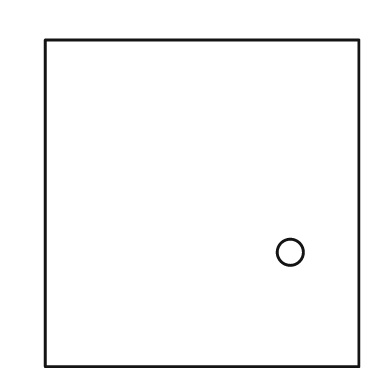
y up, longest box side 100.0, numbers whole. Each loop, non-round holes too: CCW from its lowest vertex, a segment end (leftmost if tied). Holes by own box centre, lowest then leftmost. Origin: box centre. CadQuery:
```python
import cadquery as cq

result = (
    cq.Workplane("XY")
    .moveTo(-48.0, -50.0)
    .lineTo(48.0, -50.0)
    .lineTo(48.0, 50.0)
    .lineTo(-48.0, 50.0)
    .close()
    .moveTo(27.0, -15.0)
    .circle(4.0)
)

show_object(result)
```